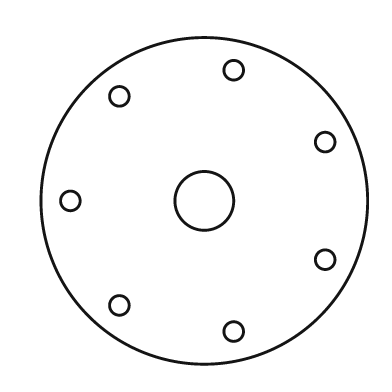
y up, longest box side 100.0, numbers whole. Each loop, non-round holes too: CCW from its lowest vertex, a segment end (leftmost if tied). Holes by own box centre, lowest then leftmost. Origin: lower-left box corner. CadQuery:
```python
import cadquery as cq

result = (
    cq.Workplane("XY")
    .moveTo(50.0, 50.0)
    .circle(50.0)
    .moveTo(59.0, 10.0)
    .circle(3.0)
    .moveTo(24.0, 18.0)
    .circle(3.0)
    .moveTo(87.0, 32.0)
    .circle(3.0)
    .moveTo(9.0, 50.0)
    .circle(3.0)
    .moveTo(50.0, 50.0)
    .circle(9.0)
    .moveTo(87.0, 68.0)
    .circle(3.0)
    .moveTo(24.0, 82.0)
    .circle(3.0)
    .moveTo(59.0, 90.0)
    .circle(3.0)
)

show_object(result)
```